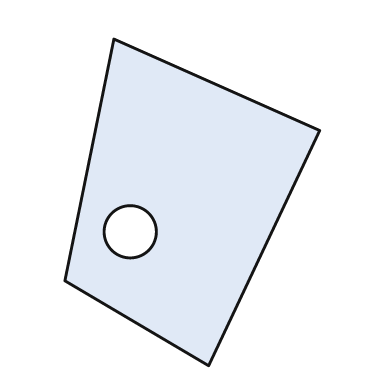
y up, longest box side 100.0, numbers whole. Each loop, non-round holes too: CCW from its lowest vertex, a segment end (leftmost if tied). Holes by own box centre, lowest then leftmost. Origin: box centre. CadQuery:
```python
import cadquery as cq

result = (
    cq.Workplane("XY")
    .moveTo(5.0, -50.0)
    .lineTo(39.0, 22.0)
    .lineTo(-24.0, 50.0)
    .lineTo(-39.0, -24.0)
    .close()
    .moveTo(-19.0, -9.0)
    .circle(8.0)
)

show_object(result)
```